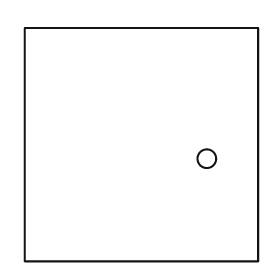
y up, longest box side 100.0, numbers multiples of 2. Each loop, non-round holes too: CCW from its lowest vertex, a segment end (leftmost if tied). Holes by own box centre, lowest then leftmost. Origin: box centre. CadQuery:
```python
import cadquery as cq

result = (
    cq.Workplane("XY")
    .moveTo(-50.0, -50.0)
    .lineTo(50.0, -50.0)
    .lineTo(50.0, 50.0)
    .lineTo(-50.0, 50.0)
    .close()
    .moveTo(28.0, -6.0)
    .circle(4.0)
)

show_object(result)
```